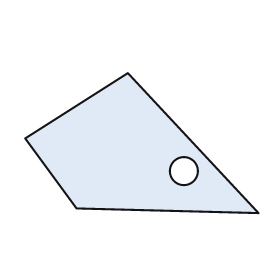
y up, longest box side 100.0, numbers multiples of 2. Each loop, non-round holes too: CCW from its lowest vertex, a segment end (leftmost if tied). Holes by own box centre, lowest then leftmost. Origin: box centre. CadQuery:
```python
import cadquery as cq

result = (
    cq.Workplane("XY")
    .moveTo(50.0, -30.0)
    .lineTo(-6.0, 30.0)
    .lineTo(-50.0, 2.0)
    .lineTo(-28.0, -28.0)
    .close()
    .moveTo(18.0, -12.0)
    .circle(6.0)
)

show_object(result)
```